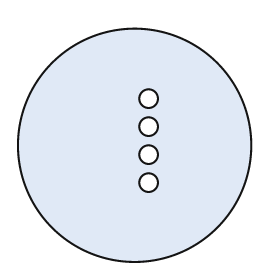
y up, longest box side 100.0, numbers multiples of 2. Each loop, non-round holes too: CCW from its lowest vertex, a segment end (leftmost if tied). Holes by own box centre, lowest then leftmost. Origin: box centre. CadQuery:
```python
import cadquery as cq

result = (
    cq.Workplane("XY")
    .moveTo(0.0, 0.0)
    .circle(50.0)
    .moveTo(6.0, -16.0)
    .circle(4.0)
    .moveTo(6.0, -4.0)
    .circle(4.0)
    .moveTo(6.0, 8.0)
    .circle(4.0)
    .moveTo(6.0, 20.0)
    .circle(4.0)
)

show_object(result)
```